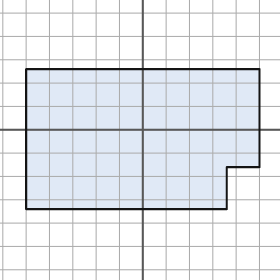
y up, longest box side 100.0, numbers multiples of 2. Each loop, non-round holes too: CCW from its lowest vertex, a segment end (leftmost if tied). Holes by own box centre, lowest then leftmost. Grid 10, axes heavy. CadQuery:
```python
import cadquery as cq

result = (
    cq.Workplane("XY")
    .moveTo(-50.0, -34.0)
    .lineTo(36.0, -34.0)
    .lineTo(36.0, -16.0)
    .lineTo(50.0, -16.0)
    .lineTo(50.0, 26.0)
    .lineTo(-50.0, 26.0)
    .close()
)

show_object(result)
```